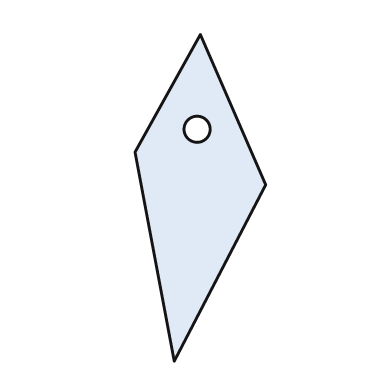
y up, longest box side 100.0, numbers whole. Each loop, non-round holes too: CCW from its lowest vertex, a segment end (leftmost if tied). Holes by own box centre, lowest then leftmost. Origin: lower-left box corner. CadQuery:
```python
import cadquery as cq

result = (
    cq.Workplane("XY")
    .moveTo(12.0, 0.0)
    .lineTo(40.0, 54.0)
    .lineTo(20.0, 100.0)
    .lineTo(0.0, 64.0)
    .close()
    .moveTo(19.0, 71.0)
    .circle(4.0)
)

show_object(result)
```